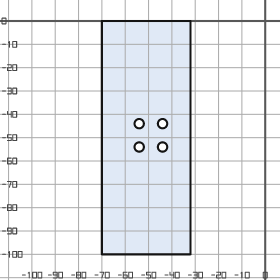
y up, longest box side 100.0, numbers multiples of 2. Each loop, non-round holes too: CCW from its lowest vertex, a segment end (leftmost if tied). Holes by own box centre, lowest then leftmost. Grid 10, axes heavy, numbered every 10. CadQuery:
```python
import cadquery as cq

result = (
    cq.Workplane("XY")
    .moveTo(-70.0, -100.0)
    .lineTo(-32.0, -100.0)
    .lineTo(-32.0, 0.0)
    .lineTo(-70.0, 0.0)
    .close()
    .moveTo(-54.0, -54.0)
    .circle(2.0)
    .moveTo(-44.0, -54.0)
    .circle(2.0)
    .moveTo(-54.0, -44.0)
    .circle(2.0)
    .moveTo(-44.0, -44.0)
    .circle(2.0)
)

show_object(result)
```